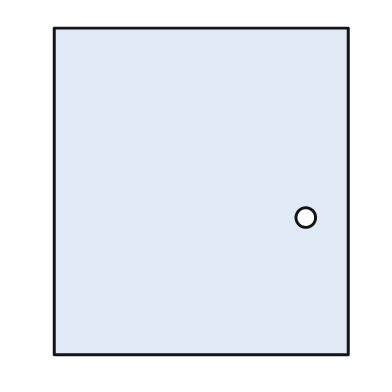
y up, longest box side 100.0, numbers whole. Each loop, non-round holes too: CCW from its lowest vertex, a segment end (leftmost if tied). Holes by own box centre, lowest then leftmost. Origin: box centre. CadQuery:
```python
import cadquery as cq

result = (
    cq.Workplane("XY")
    .moveTo(-45.0, -50.0)
    .lineTo(45.0, -50.0)
    .lineTo(45.0, 50.0)
    .lineTo(-45.0, 50.0)
    .close()
    .moveTo(32.0, -8.0)
    .circle(3.0)
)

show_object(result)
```